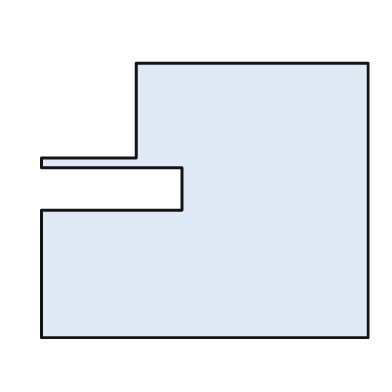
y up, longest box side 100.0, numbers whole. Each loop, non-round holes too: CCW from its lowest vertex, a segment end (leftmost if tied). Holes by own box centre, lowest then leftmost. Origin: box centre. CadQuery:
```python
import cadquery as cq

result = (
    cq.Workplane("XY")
    .moveTo(-50.0, -42.0)
    .lineTo(50.0, -42.0)
    .lineTo(50.0, 42.0)
    .lineTo(-21.0, 42.0)
    .lineTo(-21.0, 13.0)
    .lineTo(-50.0, 13.0)
    .lineTo(-50.0, 10.0)
    .lineTo(-7.0, 10.0)
    .lineTo(-7.0, -3.0)
    .lineTo(-50.0, -3.0)
    .close()
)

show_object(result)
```